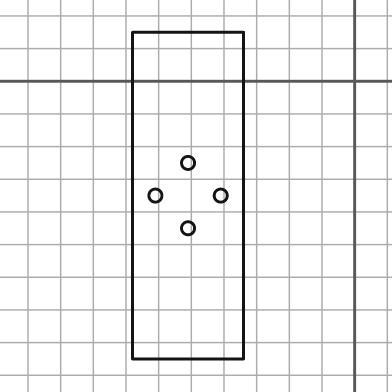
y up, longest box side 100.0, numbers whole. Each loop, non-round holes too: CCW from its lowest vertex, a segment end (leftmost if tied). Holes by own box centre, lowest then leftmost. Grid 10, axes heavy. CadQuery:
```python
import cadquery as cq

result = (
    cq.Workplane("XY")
    .moveTo(-68.0, -85.0)
    .lineTo(-34.0, -85.0)
    .lineTo(-34.0, 15.0)
    .lineTo(-68.0, 15.0)
    .close()
    .moveTo(-51.0, -45.0)
    .circle(2.0)
    .moveTo(-61.0, -35.0)
    .circle(2.0)
    .moveTo(-41.0, -35.0)
    .circle(2.0)
    .moveTo(-51.0, -25.0)
    .circle(2.0)
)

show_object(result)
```